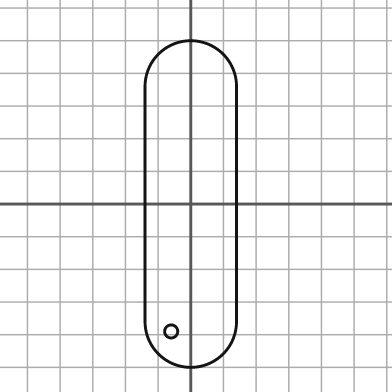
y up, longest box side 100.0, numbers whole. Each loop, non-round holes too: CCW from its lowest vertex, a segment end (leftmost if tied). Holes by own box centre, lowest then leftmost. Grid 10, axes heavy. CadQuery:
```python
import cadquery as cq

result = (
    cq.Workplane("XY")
    .moveTo(-14.0, -36.0)
    .threePointArc((0.0, -50.0), (14.0, -36.0))
    .lineTo(14.0, 36.0)
    .threePointArc((0.0, 50.0), (-14.0, 36.0))
    .close()
    .moveTo(-6.0, -39.0)
    .circle(2.0)
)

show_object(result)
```